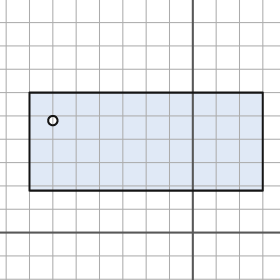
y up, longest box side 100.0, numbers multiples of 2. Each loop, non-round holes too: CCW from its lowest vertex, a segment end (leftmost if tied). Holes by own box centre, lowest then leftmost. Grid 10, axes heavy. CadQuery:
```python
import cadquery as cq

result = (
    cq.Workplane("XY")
    .moveTo(-70.0, 18.0)
    .lineTo(30.0, 18.0)
    .lineTo(30.0, 60.0)
    .lineTo(-70.0, 60.0)
    .close()
    .moveTo(-60.0, 48.0)
    .circle(2.0)
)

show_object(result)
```